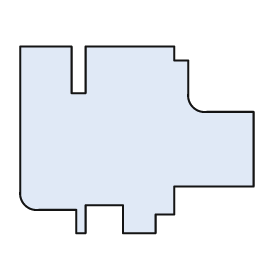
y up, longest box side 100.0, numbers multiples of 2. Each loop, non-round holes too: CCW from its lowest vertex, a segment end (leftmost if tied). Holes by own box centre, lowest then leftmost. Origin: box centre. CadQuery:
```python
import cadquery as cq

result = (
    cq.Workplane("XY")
    .moveTo(-26.0, -40.0)
    .lineTo(-22.0, -40.0)
    .lineTo(-22.0, -28.0)
    .lineTo(-6.0, -28.0)
    .lineTo(-6.0, -40.0)
    .lineTo(8.0, -40.0)
    .lineTo(8.0, -32.0)
    .lineTo(16.0, -32.0)
    .lineTo(16.0, -20.0)
    .lineTo(50.0, -20.0)
    .lineTo(50.0, 12.0)
    .lineTo(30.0, 12.0)
    .threePointArc((24.0, 14.0), (22.0, 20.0))
    .lineTo(22.0, 34.0)
    .lineTo(16.0, 34.0)
    .lineTo(16.0, 40.0)
    .lineTo(-22.0, 40.0)
    .lineTo(-22.0, 20.0)
    .lineTo(-28.0, 20.0)
    .lineTo(-28.0, 40.0)
    .lineTo(-50.0, 40.0)
    .lineTo(-50.0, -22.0)
    .threePointArc((-48.0, -28.0), (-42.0, -30.0))
    .lineTo(-26.0, -30.0)
    .close()
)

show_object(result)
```